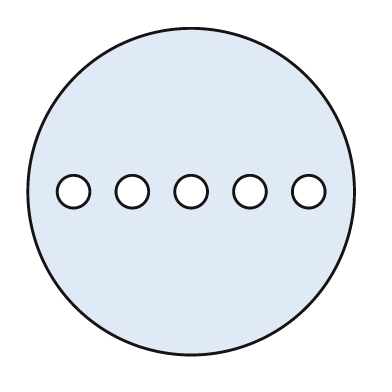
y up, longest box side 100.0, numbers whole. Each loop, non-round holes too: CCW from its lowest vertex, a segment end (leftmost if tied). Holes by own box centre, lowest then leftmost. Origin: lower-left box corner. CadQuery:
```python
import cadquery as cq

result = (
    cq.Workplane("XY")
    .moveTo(50.0, 50.0)
    .circle(50.0)
    .moveTo(14.0, 50.0)
    .circle(5.0)
    .moveTo(32.0, 50.0)
    .circle(5.0)
    .moveTo(50.0, 50.0)
    .circle(5.0)
    .moveTo(68.0, 50.0)
    .circle(5.0)
    .moveTo(86.0, 50.0)
    .circle(5.0)
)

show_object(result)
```